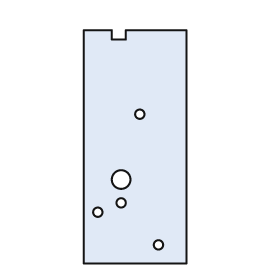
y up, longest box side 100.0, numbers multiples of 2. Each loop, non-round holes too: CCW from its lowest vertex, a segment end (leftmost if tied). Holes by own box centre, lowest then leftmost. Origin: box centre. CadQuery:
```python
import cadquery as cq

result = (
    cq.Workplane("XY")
    .moveTo(-22.0, -50.0)
    .lineTo(22.0, -50.0)
    .lineTo(22.0, 50.0)
    .lineTo(-4.0, 50.0)
    .lineTo(-4.0, 46.0)
    .lineTo(-10.0, 46.0)
    .lineTo(-10.0, 50.0)
    .lineTo(-22.0, 50.0)
    .close()
    .moveTo(10.0, -42.0)
    .circle(2.0)
    .moveTo(-16.0, -28.0)
    .circle(2.0)
    .moveTo(-6.0, -24.0)
    .circle(2.0)
    .moveTo(-6.0, -14.0)
    .circle(4.0)
    .moveTo(2.0, 14.0)
    .circle(2.0)
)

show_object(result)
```